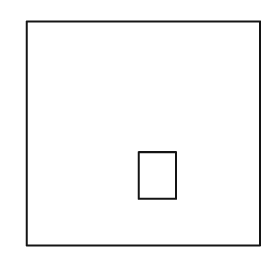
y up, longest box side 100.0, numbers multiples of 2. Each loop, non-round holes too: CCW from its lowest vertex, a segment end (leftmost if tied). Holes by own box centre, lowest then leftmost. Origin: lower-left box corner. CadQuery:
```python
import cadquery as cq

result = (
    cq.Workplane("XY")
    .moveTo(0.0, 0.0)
    .lineTo(100.0, 0.0)
    .lineTo(100.0, 96.0)
    .lineTo(0.0, 96.0)
    .close()
    .moveTo(48.0, 20.0)
    .lineTo(64.0, 20.0)
    .lineTo(64.0, 40.0)
    .lineTo(48.0, 40.0)
    .close()
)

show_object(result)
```